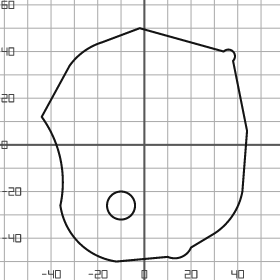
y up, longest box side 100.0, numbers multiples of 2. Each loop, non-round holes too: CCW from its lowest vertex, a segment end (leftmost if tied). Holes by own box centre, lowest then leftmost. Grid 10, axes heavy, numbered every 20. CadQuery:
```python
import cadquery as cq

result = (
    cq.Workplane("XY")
    .moveTo(-12.0, -50.0)
    .lineTo(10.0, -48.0)
    .threePointArc((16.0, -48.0), (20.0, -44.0))
    .lineTo(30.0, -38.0)
    .threePointArc((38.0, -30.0), (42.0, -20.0))
    .lineTo(44.0, 6.0)
    .lineTo(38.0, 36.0)
    .threePointArc((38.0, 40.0), (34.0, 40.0))
    .lineTo(-2.0, 50.0)
    .lineTo(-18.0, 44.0)
    .threePointArc((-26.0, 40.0), (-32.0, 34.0))
    .lineTo(-44.0, 12.0)
    .threePointArc((-36.0, -6.0), (-36.0, -26.0))
    .threePointArc((-28.0, -42.0), (-12.0, -50.0))
    .close()
    .moveTo(-10.0, -26.0)
    .circle(6.0)
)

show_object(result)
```